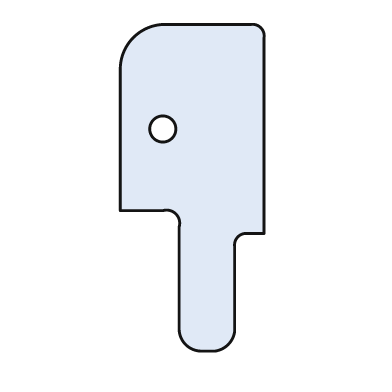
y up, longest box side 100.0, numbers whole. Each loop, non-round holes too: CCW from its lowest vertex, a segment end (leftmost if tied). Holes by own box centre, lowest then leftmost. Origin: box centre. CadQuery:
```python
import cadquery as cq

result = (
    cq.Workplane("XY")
    .moveTo(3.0, -50.0)
    .lineTo(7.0, -50.0)
    .threePointArc((11.0, -48.0), (13.0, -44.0))
    .lineTo(13.0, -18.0)
    .threePointArc((14.0, -15.0), (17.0, -14.0))
    .lineTo(22.0, -14.0)
    .lineTo(22.0, 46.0)
    .threePointArc((21.0, 49.0), (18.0, 50.0))
    .lineTo(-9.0, 50.0)
    .threePointArc((-18.0, 46.0), (-22.0, 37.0))
    .lineTo(-22.0, -7.0)
    .lineTo(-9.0, -7.0)
    .threePointArc((-5.0, -8.0), (-4.0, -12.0))
    .lineTo(-4.0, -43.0)
    .threePointArc((-2.0, -48.0), (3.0, -50.0))
    .close()
    .moveTo(-9.0, 18.0)
    .circle(4.0)
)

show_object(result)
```